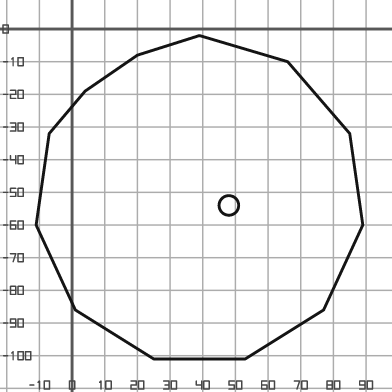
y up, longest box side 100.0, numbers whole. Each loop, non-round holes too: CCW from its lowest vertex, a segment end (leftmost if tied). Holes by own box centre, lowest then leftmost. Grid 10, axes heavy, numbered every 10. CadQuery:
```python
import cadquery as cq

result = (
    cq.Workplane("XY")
    .moveTo(25.0, -101.0)
    .lineTo(53.0, -101.0)
    .lineTo(77.0, -86.0)
    .lineTo(89.0, -60.0)
    .lineTo(85.0, -32.0)
    .lineTo(66.0, -10.0)
    .lineTo(39.0, -2.0)
    .lineTo(20.0, -8.0)
    .lineTo(4.0, -19.0)
    .lineTo(-7.0, -32.0)
    .lineTo(-11.0, -60.0)
    .lineTo(1.0, -86.0)
    .close()
    .moveTo(48.0, -54.0)
    .circle(3.0)
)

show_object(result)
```